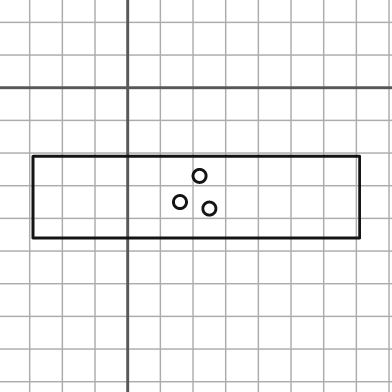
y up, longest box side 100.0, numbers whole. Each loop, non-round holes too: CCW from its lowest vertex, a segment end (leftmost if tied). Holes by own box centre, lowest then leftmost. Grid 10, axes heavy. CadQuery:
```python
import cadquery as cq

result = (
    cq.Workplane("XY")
    .moveTo(-29.0, -46.0)
    .lineTo(71.0, -46.0)
    .lineTo(71.0, -21.0)
    .lineTo(-29.0, -21.0)
    .close()
    .moveTo(25.0, -37.0)
    .circle(2.0)
    .moveTo(16.0, -35.0)
    .circle(2.0)
    .moveTo(22.0, -27.0)
    .circle(2.0)
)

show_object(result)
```